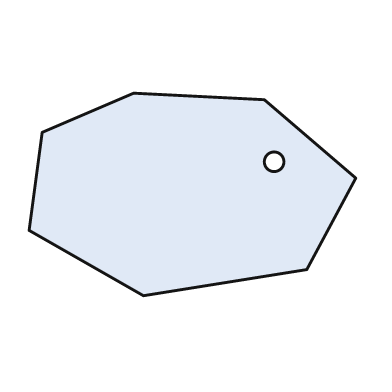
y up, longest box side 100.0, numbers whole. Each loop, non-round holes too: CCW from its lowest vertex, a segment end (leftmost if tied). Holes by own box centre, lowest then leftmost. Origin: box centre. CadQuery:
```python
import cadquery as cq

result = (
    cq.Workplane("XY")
    .moveTo(-15.0, -31.0)
    .lineTo(35.0, -23.0)
    .lineTo(50.0, 5.0)
    .lineTo(22.0, 29.0)
    .lineTo(-18.0, 31.0)
    .lineTo(-46.0, 19.0)
    .lineTo(-50.0, -11.0)
    .close()
    .moveTo(25.0, 10.0)
    .circle(3.0)
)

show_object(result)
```